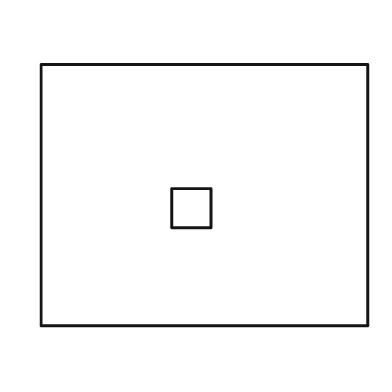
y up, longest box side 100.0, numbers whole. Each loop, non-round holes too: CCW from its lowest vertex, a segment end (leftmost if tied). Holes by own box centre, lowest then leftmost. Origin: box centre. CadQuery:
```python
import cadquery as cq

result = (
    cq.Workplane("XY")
    .moveTo(-50.0, -40.0)
    .lineTo(50.0, -40.0)
    .lineTo(50.0, 40.0)
    .lineTo(-50.0, 40.0)
    .close()
    .moveTo(-10.0, -10.0)
    .lineTo(2.0, -10.0)
    .lineTo(2.0, 2.0)
    .lineTo(-10.0, 2.0)
    .close()
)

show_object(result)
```